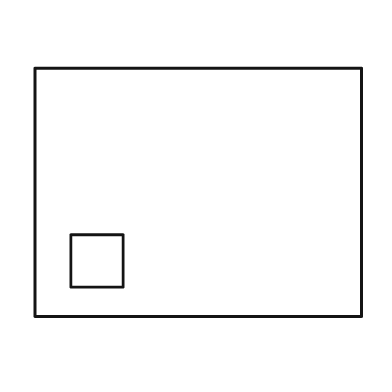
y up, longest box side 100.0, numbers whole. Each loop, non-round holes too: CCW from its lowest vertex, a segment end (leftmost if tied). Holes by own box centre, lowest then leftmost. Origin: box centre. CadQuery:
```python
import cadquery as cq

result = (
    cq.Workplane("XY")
    .moveTo(-50.0, -38.0)
    .lineTo(50.0, -38.0)
    .lineTo(50.0, 38.0)
    .lineTo(-50.0, 38.0)
    .close()
    .moveTo(-39.0, -29.0)
    .lineTo(-23.0, -29.0)
    .lineTo(-23.0, -13.0)
    .lineTo(-39.0, -13.0)
    .close()
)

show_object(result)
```